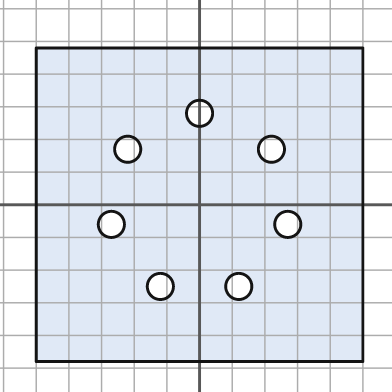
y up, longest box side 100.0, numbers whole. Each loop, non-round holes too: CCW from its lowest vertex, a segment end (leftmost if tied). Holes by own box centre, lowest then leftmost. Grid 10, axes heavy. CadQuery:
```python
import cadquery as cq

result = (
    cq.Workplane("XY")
    .moveTo(-50.0, -48.0)
    .lineTo(50.0, -48.0)
    .lineTo(50.0, 48.0)
    .lineTo(-50.0, 48.0)
    .close()
    .moveTo(-12.0, -25.0)
    .circle(4.0)
    .moveTo(12.0, -25.0)
    .circle(4.0)
    .moveTo(-27.0, -6.0)
    .circle(4.0)
    .moveTo(27.0, -6.0)
    .circle(4.0)
    .moveTo(-22.0, 17.0)
    .circle(4.0)
    .moveTo(22.0, 17.0)
    .circle(4.0)
    .moveTo(0.0, 28.0)
    .circle(4.0)
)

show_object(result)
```